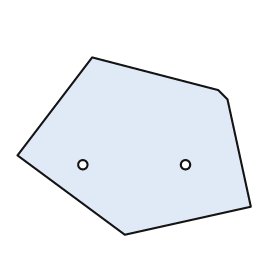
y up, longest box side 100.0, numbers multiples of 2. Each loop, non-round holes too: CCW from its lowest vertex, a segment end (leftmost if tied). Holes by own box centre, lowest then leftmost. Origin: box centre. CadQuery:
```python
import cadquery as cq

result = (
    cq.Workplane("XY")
    .moveTo(-4.0, -38.0)
    .lineTo(50.0, -26.0)
    .lineTo(40.0, 20.0)
    .lineTo(36.0, 24.0)
    .lineTo(-18.0, 38.0)
    .lineTo(-50.0, -4.0)
    .close()
    .moveTo(-22.0, -8.0)
    .circle(2.0)
    .moveTo(22.0, -8.0)
    .circle(2.0)
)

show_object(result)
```